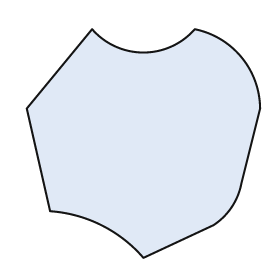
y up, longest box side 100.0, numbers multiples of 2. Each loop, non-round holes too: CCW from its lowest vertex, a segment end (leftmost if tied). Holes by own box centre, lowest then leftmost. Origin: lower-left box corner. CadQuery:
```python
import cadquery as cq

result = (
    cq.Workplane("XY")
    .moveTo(50.0, 0.0)
    .lineTo(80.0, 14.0)
    .threePointArc((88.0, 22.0), (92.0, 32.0))
    .lineTo(100.0, 64.0)
    .threePointArc((92.0, 86.0), (72.0, 98.0))
    .threePointArc((50.0, 88.0), (28.0, 98.0))
    .lineTo(0.0, 64.0)
    .lineTo(10.0, 20.0)
    .threePointArc((32.0, 14.0), (50.0, 0.0))
    .close()
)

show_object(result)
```